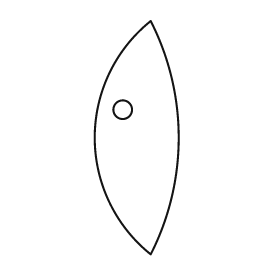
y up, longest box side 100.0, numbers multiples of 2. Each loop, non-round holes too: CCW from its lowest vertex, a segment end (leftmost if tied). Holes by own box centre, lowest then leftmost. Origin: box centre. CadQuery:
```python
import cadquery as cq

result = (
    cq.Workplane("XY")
    .moveTo(6.0, -50.0)
    .threePointArc((18.0, 0.0), (6.0, 50.0))
    .threePointArc((-18.0, 0.0), (6.0, -50.0))
    .close()
    .moveTo(-6.0, 12.0)
    .circle(4.0)
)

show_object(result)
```